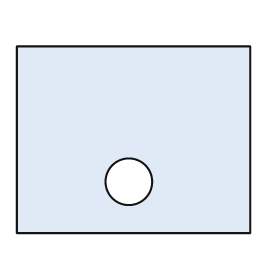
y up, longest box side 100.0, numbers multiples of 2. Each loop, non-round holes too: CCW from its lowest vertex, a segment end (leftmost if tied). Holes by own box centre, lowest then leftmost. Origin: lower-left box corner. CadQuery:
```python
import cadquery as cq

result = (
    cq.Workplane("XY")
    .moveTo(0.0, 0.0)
    .lineTo(100.0, 0.0)
    .lineTo(100.0, 80.0)
    .lineTo(0.0, 80.0)
    .close()
    .moveTo(48.0, 22.0)
    .circle(10.0)
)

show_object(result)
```